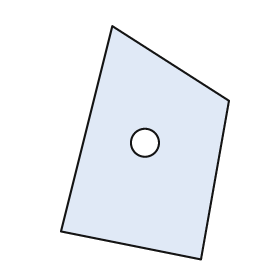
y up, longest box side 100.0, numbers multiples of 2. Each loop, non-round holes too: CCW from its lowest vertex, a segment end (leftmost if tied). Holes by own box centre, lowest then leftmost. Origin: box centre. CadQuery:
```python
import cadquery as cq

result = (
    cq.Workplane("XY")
    .moveTo(24.0, -50.0)
    .lineTo(36.0, 18.0)
    .lineTo(-14.0, 50.0)
    .lineTo(-36.0, -38.0)
    .close()
    .moveTo(0.0, 0.0)
    .circle(6.0)
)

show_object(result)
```